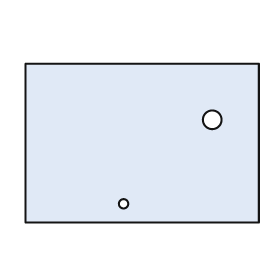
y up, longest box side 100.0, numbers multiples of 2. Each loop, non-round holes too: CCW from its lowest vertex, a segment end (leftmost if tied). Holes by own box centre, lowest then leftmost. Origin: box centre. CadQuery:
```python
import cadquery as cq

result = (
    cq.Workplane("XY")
    .moveTo(-50.0, -34.0)
    .lineTo(50.0, -34.0)
    .lineTo(50.0, 34.0)
    .lineTo(-50.0, 34.0)
    .close()
    .moveTo(-8.0, -26.0)
    .circle(2.0)
    .moveTo(30.0, 10.0)
    .circle(4.0)
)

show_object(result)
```